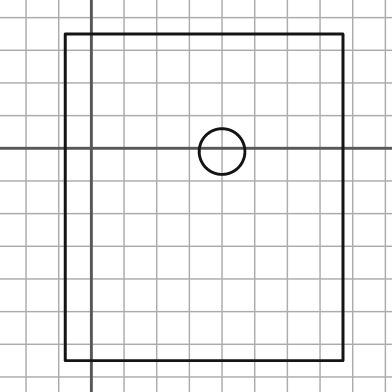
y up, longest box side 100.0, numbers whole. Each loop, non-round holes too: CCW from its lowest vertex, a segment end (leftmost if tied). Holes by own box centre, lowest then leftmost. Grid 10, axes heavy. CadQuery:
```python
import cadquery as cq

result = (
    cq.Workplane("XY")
    .moveTo(-8.0, -65.0)
    .lineTo(77.0, -65.0)
    .lineTo(77.0, 35.0)
    .lineTo(-8.0, 35.0)
    .close()
    .moveTo(40.0, -1.0)
    .circle(7.0)
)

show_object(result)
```